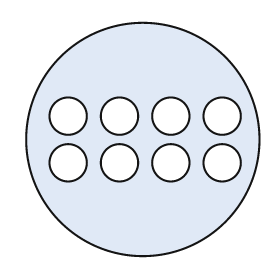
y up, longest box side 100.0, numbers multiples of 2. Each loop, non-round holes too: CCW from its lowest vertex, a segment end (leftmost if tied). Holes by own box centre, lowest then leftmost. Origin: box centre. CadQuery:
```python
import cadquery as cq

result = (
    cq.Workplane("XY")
    .moveTo(0.0, 0.0)
    .circle(50.0)
    .moveTo(-32.0, -10.0)
    .circle(8.0)
    .moveTo(-10.0, -10.0)
    .circle(8.0)
    .moveTo(12.0, -10.0)
    .circle(8.0)
    .moveTo(34.0, -10.0)
    .circle(8.0)
    .moveTo(-32.0, 10.0)
    .circle(8.0)
    .moveTo(-10.0, 10.0)
    .circle(8.0)
    .moveTo(12.0, 10.0)
    .circle(8.0)
    .moveTo(34.0, 10.0)
    .circle(8.0)
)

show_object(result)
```